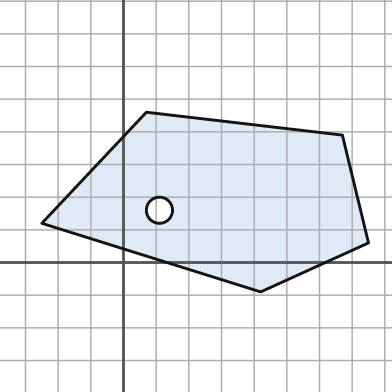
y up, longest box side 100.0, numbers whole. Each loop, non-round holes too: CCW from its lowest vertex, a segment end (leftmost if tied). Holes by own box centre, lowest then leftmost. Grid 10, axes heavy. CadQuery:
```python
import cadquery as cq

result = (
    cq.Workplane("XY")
    .moveTo(42.0, -9.0)
    .lineTo(75.0, 6.0)
    .lineTo(67.0, 39.0)
    .lineTo(7.0, 46.0)
    .lineTo(-25.0, 12.0)
    .close()
    .moveTo(11.0, 16.0)
    .circle(4.0)
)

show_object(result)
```